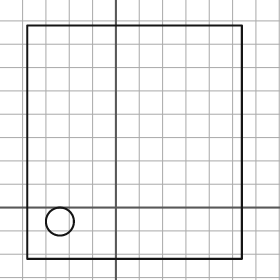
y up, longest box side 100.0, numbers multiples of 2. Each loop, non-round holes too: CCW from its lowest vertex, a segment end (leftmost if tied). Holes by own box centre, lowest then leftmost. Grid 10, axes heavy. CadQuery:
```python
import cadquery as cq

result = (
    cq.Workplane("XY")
    .moveTo(-38.0, -22.0)
    .lineTo(54.0, -22.0)
    .lineTo(54.0, 78.0)
    .lineTo(-38.0, 78.0)
    .close()
    .moveTo(-24.0, -6.0)
    .circle(6.0)
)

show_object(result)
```